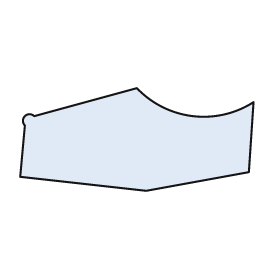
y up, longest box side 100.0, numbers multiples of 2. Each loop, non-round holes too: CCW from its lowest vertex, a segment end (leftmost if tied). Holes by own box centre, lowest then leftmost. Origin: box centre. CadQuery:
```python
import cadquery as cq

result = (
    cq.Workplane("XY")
    .moveTo(4.0, -22.0)
    .lineTo(48.0, -14.0)
    .lineTo(50.0, 16.0)
    .threePointArc((24.0, 10.0), (0.0, 22.0))
    .lineTo(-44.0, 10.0)
    .threePointArc((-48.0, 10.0), (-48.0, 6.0))
    .lineTo(-50.0, -16.0)
    .close()
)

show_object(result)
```